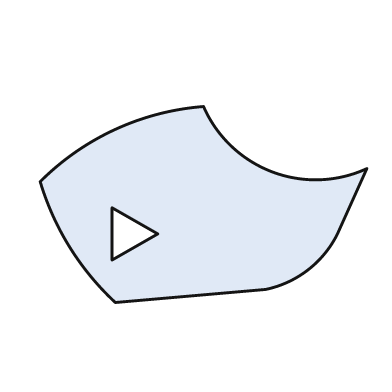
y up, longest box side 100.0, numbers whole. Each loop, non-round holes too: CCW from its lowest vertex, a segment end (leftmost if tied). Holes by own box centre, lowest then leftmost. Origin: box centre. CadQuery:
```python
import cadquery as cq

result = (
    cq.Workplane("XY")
    .moveTo(-27.0, -30.0)
    .lineTo(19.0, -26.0)
    .threePointArc((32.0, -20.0), (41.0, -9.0))
    .lineTo(50.0, 11.0)
    .threePointArc((21.0, 10.0), (0.0, 30.0))
    .threePointArc((-27.0, 23.0), (-50.0, 7.0))
    .threePointArc((-41.0, -13.0), (-27.0, -30.0))
    .close()
    .moveTo(-28.0, -17.0)
    .lineTo(-14.0, -9.0)
    .lineTo(-28.0, -1.0)
    .close()
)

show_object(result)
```